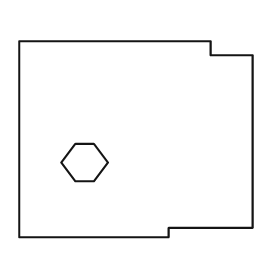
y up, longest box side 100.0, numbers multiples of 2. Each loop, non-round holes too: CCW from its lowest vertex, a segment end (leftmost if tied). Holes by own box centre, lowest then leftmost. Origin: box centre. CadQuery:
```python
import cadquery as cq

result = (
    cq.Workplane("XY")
    .moveTo(-50.0, -42.0)
    .lineTo(14.0, -42.0)
    .lineTo(14.0, -38.0)
    .lineTo(50.0, -38.0)
    .lineTo(50.0, 36.0)
    .lineTo(32.0, 36.0)
    .lineTo(32.0, 42.0)
    .lineTo(-50.0, 42.0)
    .close()
    .moveTo(-26.0, -18.0)
    .lineTo(-18.0, -18.0)
    .lineTo(-12.0, -10.0)
    .lineTo(-18.0, -2.0)
    .lineTo(-26.0, -2.0)
    .lineTo(-32.0, -10.0)
    .close()
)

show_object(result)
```